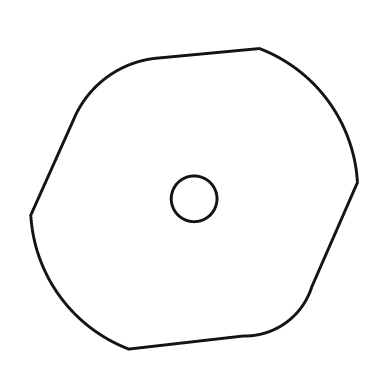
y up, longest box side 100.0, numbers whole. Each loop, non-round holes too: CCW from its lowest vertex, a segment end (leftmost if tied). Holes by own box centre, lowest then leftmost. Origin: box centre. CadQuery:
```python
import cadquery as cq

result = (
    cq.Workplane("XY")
    .moveTo(-20.0, -46.0)
    .lineTo(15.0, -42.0)
    .threePointArc((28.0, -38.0), (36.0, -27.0))
    .lineTo(50.0, 5.0)
    .threePointArc((41.0, 30.0), (20.0, 46.0))
    .lineTo(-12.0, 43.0)
    .threePointArc((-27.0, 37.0), (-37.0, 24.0))
    .lineTo(-50.0, -5.0)
    .threePointArc((-41.0, -30.0), (-20.0, -46.0))
    .close()
    .moveTo(0.0, 0.0)
    .circle(7.0)
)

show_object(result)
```